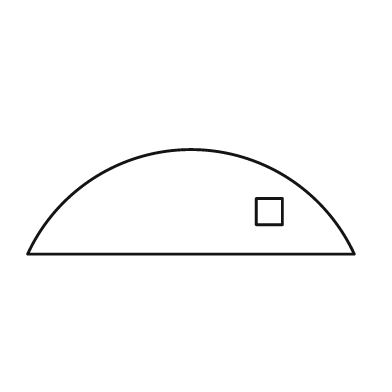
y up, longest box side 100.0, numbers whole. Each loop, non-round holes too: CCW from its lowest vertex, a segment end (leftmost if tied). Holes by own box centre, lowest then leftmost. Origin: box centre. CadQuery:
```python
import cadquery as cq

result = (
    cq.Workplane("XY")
    .moveTo(-50.0, -16.0)
    .lineTo(50.0, -16.0)
    .threePointArc((0.0, 16.0), (-50.0, -16.0))
    .close()
    .moveTo(20.0, -7.0)
    .lineTo(28.0, -7.0)
    .lineTo(28.0, 1.0)
    .lineTo(20.0, 1.0)
    .close()
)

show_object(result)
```